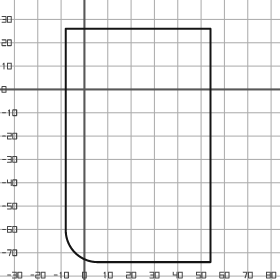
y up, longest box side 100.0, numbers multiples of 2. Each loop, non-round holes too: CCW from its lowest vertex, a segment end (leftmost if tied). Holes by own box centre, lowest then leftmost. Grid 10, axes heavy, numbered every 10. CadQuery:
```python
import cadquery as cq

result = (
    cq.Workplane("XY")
    .moveTo(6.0, -74.0)
    .lineTo(54.0, -74.0)
    .lineTo(54.0, 26.0)
    .lineTo(-8.0, 26.0)
    .lineTo(-8.0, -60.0)
    .threePointArc((-4.0, -70.0), (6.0, -74.0))
    .close()
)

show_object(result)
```